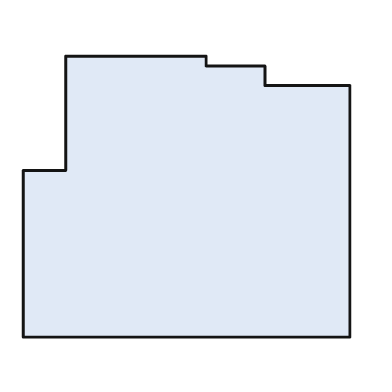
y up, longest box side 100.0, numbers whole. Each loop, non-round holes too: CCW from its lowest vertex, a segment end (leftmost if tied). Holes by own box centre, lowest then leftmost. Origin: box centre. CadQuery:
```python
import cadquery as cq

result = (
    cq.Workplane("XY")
    .moveTo(-50.0, -43.0)
    .lineTo(50.0, -43.0)
    .lineTo(50.0, 34.0)
    .lineTo(24.0, 34.0)
    .lineTo(24.0, 40.0)
    .lineTo(6.0, 40.0)
    .lineTo(6.0, 43.0)
    .lineTo(-37.0, 43.0)
    .lineTo(-37.0, 8.0)
    .lineTo(-50.0, 8.0)
    .close()
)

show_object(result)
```